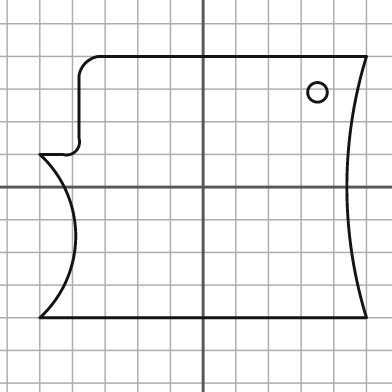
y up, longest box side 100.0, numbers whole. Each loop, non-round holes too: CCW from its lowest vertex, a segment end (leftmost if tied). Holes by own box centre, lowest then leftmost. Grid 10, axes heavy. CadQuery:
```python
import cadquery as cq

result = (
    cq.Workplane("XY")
    .moveTo(-50.0, -40.0)
    .lineTo(50.0, -40.0)
    .threePointArc((44.0, 0.0), (50.0, 40.0))
    .lineTo(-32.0, 40.0)
    .threePointArc((-36.0, 38.0), (-38.0, 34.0))
    .lineTo(-38.0, 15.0)
    .threePointArc((-39.0, 11.0), (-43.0, 10.0))
    .lineTo(-50.0, 10.0)
    .threePointArc((-39.0, -15.0), (-50.0, -40.0))
    .close()
    .moveTo(35.0, 29.0)
    .circle(3.0)
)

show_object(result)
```